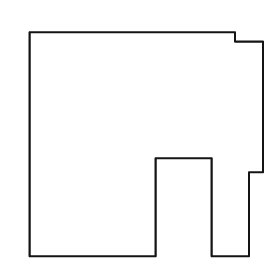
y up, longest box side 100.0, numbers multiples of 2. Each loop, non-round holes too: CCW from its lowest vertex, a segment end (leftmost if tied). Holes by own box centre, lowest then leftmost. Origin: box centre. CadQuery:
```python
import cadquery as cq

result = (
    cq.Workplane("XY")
    .moveTo(-50.0, -48.0)
    .lineTo(4.0, -48.0)
    .lineTo(4.0, -6.0)
    .lineTo(28.0, -6.0)
    .lineTo(28.0, -48.0)
    .lineTo(44.0, -48.0)
    .lineTo(44.0, -12.0)
    .lineTo(50.0, -12.0)
    .lineTo(50.0, 44.0)
    .lineTo(38.0, 44.0)
    .lineTo(38.0, 48.0)
    .lineTo(-50.0, 48.0)
    .close()
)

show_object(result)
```